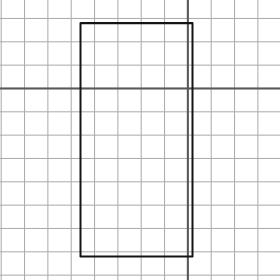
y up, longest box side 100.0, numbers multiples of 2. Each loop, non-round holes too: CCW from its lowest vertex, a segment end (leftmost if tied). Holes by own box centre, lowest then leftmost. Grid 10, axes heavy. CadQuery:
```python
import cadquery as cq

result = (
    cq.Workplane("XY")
    .moveTo(-46.0, -72.0)
    .lineTo(2.0, -72.0)
    .lineTo(2.0, 28.0)
    .lineTo(-46.0, 28.0)
    .close()
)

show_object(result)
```